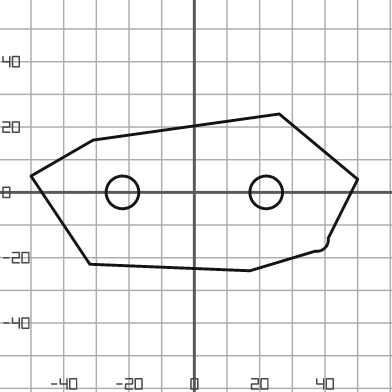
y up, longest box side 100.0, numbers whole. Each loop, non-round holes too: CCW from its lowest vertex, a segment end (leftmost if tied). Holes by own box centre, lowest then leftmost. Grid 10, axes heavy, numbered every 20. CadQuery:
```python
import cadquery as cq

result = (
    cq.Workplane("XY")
    .moveTo(17.0, -24.0)
    .lineTo(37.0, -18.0)
    .threePointArc((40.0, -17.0), (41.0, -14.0))
    .lineTo(50.0, 4.0)
    .lineTo(26.0, 24.0)
    .lineTo(-31.0, 16.0)
    .lineTo(-50.0, 5.0)
    .lineTo(-32.0, -22.0)
    .close()
    .moveTo(-22.0, 0.0)
    .circle(5.0)
    .moveTo(22.0, 0.0)
    .circle(5.0)
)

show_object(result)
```